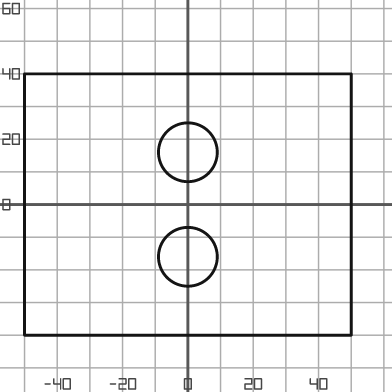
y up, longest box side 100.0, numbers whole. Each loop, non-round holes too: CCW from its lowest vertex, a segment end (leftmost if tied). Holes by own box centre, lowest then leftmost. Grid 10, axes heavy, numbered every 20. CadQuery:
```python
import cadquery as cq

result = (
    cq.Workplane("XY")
    .moveTo(-50.0, -40.0)
    .lineTo(50.0, -40.0)
    .lineTo(50.0, 40.0)
    .lineTo(-50.0, 40.0)
    .close()
    .moveTo(0.0, -16.0)
    .circle(9.0)
    .moveTo(0.0, 16.0)
    .circle(9.0)
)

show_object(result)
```